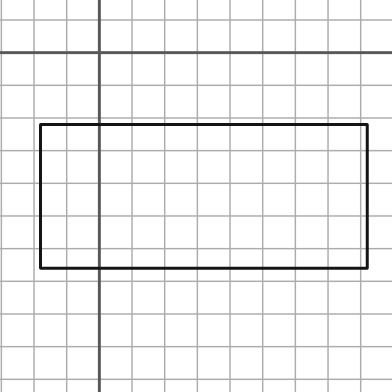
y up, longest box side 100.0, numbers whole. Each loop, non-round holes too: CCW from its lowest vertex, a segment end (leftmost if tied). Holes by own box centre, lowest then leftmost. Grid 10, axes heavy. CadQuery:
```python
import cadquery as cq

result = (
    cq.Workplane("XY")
    .moveTo(-18.0, -66.0)
    .lineTo(82.0, -66.0)
    .lineTo(82.0, -22.0)
    .lineTo(-18.0, -22.0)
    .close()
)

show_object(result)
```